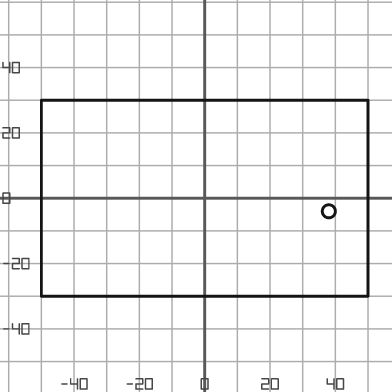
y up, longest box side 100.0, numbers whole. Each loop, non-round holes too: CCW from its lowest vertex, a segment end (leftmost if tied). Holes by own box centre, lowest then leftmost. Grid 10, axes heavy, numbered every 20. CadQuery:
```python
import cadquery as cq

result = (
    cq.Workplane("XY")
    .moveTo(-50.0, -30.0)
    .lineTo(50.0, -30.0)
    .lineTo(50.0, 30.0)
    .lineTo(-50.0, 30.0)
    .close()
    .moveTo(38.0, -4.0)
    .circle(2.0)
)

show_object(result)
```